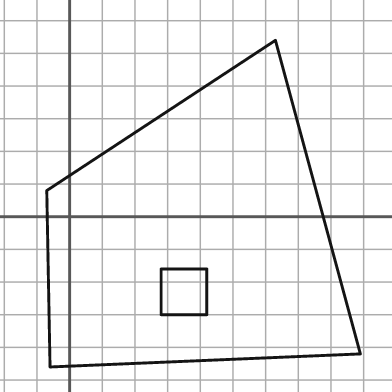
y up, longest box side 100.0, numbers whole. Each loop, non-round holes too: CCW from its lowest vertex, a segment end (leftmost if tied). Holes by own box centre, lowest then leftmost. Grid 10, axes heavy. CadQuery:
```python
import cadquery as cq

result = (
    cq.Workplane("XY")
    .moveTo(-6.0, -46.0)
    .lineTo(89.0, -42.0)
    .lineTo(63.0, 54.0)
    .lineTo(-7.0, 8.0)
    .close()
    .moveTo(28.0, -30.0)
    .lineTo(42.0, -30.0)
    .lineTo(42.0, -16.0)
    .lineTo(28.0, -16.0)
    .close()
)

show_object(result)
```